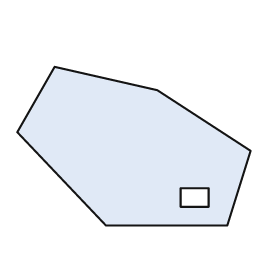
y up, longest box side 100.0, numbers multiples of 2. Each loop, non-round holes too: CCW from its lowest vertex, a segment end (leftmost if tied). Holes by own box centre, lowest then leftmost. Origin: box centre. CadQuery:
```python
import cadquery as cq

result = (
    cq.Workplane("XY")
    .moveTo(-12.0, -34.0)
    .lineTo(40.0, -34.0)
    .lineTo(50.0, -2.0)
    .lineTo(10.0, 24.0)
    .lineTo(-34.0, 34.0)
    .lineTo(-50.0, 6.0)
    .close()
    .moveTo(20.0, -26.0)
    .lineTo(32.0, -26.0)
    .lineTo(32.0, -18.0)
    .lineTo(20.0, -18.0)
    .close()
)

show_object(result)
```